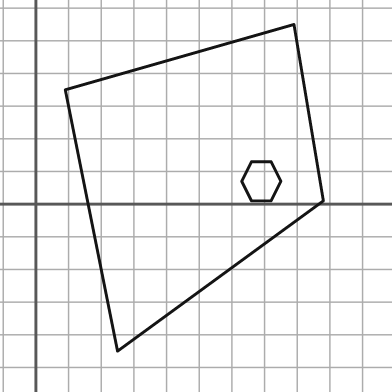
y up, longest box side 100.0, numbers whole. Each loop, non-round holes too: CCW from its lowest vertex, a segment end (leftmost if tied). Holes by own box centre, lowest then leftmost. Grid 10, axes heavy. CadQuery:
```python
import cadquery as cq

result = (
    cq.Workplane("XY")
    .moveTo(25.0, -45.0)
    .lineTo(88.0, 1.0)
    .lineTo(79.0, 55.0)
    .lineTo(9.0, 35.0)
    .close()
    .moveTo(66.0, 1.0)
    .lineTo(72.0, 1.0)
    .lineTo(75.0, 7.0)
    .lineTo(72.0, 13.0)
    .lineTo(66.0, 13.0)
    .lineTo(63.0, 7.0)
    .close()
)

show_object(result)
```